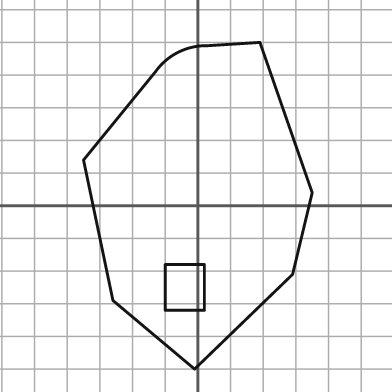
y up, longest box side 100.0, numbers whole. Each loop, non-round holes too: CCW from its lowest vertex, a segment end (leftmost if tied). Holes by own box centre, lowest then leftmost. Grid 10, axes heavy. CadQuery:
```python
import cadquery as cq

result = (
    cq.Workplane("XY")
    .moveTo(-1.0, -50.0)
    .lineTo(29.0, -21.0)
    .lineTo(35.0, 4.0)
    .lineTo(19.0, 50.0)
    .lineTo(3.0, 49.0)
    .threePointArc((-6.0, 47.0), (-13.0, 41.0))
    .lineTo(-35.0, 14.0)
    .lineTo(-26.0, -29.0)
    .close()
    .moveTo(-10.0, -32.0)
    .lineTo(2.0, -32.0)
    .lineTo(2.0, -18.0)
    .lineTo(-10.0, -18.0)
    .close()
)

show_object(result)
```